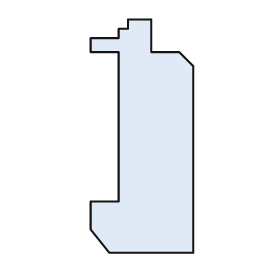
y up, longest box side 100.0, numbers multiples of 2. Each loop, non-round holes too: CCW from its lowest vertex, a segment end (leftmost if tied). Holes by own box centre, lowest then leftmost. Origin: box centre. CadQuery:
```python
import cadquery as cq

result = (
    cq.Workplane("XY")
    .moveTo(-14.0, -50.0)
    .lineTo(22.0, -50.0)
    .lineTo(22.0, 30.0)
    .lineTo(16.0, 36.0)
    .lineTo(4.0, 36.0)
    .lineTo(4.0, 50.0)
    .lineTo(-6.0, 50.0)
    .lineTo(-6.0, 46.0)
    .lineTo(-10.0, 46.0)
    .lineTo(-10.0, 42.0)
    .lineTo(-22.0, 42.0)
    .lineTo(-22.0, 36.0)
    .lineTo(-10.0, 36.0)
    .lineTo(-10.0, -28.0)
    .lineTo(-22.0, -28.0)
    .lineTo(-22.0, -40.0)
    .close()
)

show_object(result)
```